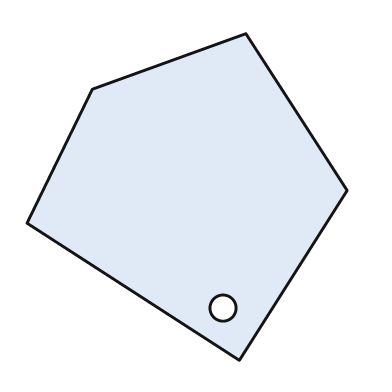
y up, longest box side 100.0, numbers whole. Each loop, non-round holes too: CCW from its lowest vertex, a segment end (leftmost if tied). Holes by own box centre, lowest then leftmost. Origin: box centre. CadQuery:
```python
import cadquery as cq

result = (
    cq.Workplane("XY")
    .moveTo(16.0, -50.0)
    .lineTo(49.0, 2.0)
    .lineTo(18.0, 50.0)
    .lineTo(-29.0, 33.0)
    .lineTo(-49.0, -8.0)
    .close()
    .moveTo(11.0, -34.0)
    .circle(4.0)
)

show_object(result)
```